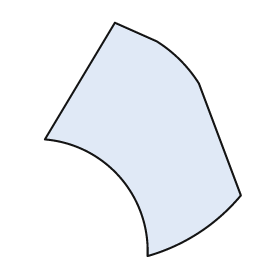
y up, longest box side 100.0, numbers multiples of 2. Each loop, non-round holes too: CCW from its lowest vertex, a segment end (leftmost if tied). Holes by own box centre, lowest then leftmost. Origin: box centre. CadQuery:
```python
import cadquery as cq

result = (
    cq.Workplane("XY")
    .moveTo(2.0, -50.0)
    .threePointArc((24.0, -40.0), (42.0, -24.0))
    .lineTo(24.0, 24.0)
    .threePointArc((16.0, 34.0), (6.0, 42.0))
    .lineTo(-12.0, 50.0)
    .lineTo(-42.0, 0.0)
    .threePointArc((-10.0, -16.0), (2.0, -50.0))
    .close()
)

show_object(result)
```